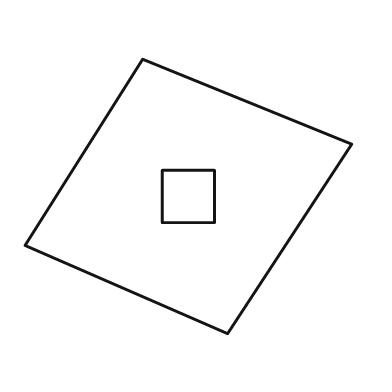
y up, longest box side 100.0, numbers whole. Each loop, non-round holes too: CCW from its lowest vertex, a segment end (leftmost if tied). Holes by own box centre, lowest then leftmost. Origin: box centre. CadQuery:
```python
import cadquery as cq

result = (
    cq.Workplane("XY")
    .moveTo(12.0, -42.0)
    .lineTo(50.0, 16.0)
    .lineTo(-14.0, 42.0)
    .lineTo(-50.0, -15.0)
    .close()
    .moveTo(-8.0, -8.0)
    .lineTo(8.0, -8.0)
    .lineTo(8.0, 8.0)
    .lineTo(-8.0, 8.0)
    .close()
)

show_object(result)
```